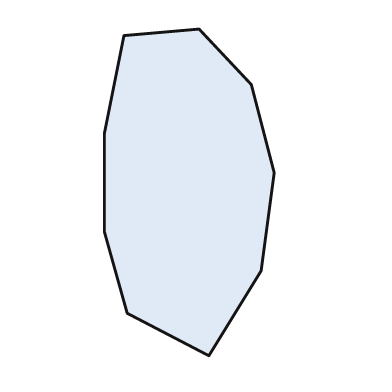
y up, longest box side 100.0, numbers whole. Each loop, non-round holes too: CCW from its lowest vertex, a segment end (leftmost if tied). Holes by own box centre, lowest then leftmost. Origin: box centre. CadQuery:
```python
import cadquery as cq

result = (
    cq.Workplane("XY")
    .moveTo(6.0, -50.0)
    .lineTo(22.0, -24.0)
    .lineTo(26.0, 6.0)
    .lineTo(19.0, 33.0)
    .lineTo(3.0, 50.0)
    .lineTo(-20.0, 48.0)
    .lineTo(-26.0, 18.0)
    .lineTo(-26.0, -12.0)
    .lineTo(-19.0, -37.0)
    .close()
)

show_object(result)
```